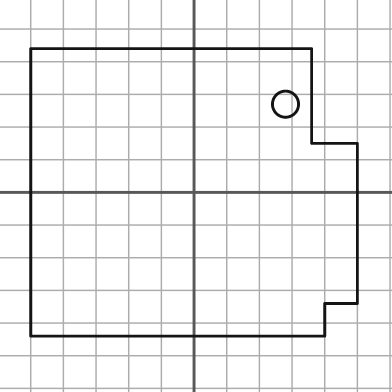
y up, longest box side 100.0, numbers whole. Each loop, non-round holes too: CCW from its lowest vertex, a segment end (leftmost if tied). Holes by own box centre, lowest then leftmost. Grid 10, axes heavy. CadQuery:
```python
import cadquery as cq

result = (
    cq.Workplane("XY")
    .moveTo(-50.0, -44.0)
    .lineTo(40.0, -44.0)
    .lineTo(40.0, -34.0)
    .lineTo(50.0, -34.0)
    .lineTo(50.0, 15.0)
    .lineTo(36.0, 15.0)
    .lineTo(36.0, 44.0)
    .lineTo(-50.0, 44.0)
    .close()
    .moveTo(28.0, 27.0)
    .circle(4.0)
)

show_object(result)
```